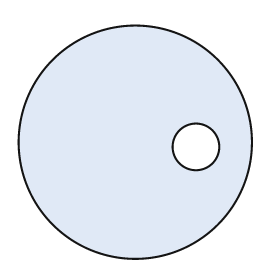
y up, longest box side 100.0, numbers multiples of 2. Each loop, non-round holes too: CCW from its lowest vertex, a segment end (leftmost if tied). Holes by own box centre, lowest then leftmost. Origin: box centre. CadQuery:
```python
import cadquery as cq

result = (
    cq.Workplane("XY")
    .moveTo(0.0, 0.0)
    .circle(50.0)
    .moveTo(26.0, -2.0)
    .circle(10.0)
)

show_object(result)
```